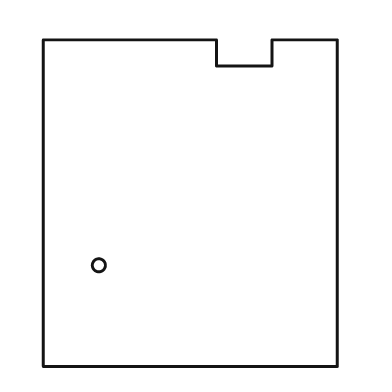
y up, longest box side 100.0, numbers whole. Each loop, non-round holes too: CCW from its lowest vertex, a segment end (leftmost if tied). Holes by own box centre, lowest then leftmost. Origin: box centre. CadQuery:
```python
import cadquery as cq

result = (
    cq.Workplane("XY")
    .moveTo(-45.0, -50.0)
    .lineTo(45.0, -50.0)
    .lineTo(45.0, 50.0)
    .lineTo(25.0, 50.0)
    .lineTo(25.0, 42.0)
    .lineTo(8.0, 42.0)
    .lineTo(8.0, 50.0)
    .lineTo(-45.0, 50.0)
    .close()
    .moveTo(-28.0, -19.0)
    .circle(2.0)
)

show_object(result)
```